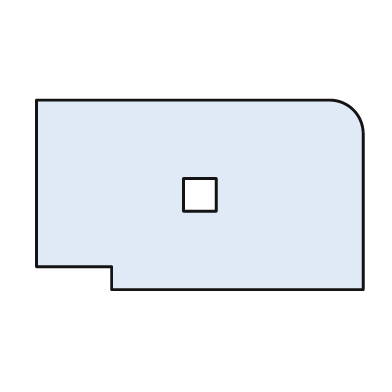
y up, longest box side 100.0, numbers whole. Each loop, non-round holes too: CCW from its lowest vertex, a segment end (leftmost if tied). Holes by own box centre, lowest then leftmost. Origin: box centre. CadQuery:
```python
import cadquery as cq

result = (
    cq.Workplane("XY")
    .moveTo(-27.0, -29.0)
    .lineTo(50.0, -29.0)
    .lineTo(50.0, 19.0)
    .threePointArc((47.0, 26.0), (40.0, 29.0))
    .lineTo(-50.0, 29.0)
    .lineTo(-50.0, -22.0)
    .lineTo(-27.0, -22.0)
    .close()
    .moveTo(-5.0, -5.0)
    .lineTo(5.0, -5.0)
    .lineTo(5.0, 5.0)
    .lineTo(-5.0, 5.0)
    .close()
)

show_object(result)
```